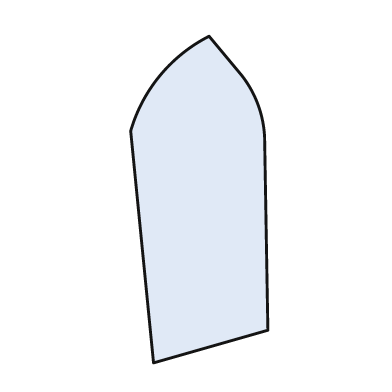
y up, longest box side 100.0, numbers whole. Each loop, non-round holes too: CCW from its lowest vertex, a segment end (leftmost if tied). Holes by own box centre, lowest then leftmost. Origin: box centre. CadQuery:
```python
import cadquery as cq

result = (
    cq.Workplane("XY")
    .moveTo(-14.0, -50.0)
    .lineTo(21.0, -40.0)
    .lineTo(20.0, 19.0)
    .threePointArc((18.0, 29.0), (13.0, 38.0))
    .lineTo(3.0, 50.0)
    .threePointArc((-12.0, 38.0), (-21.0, 21.0))
    .close()
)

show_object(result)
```